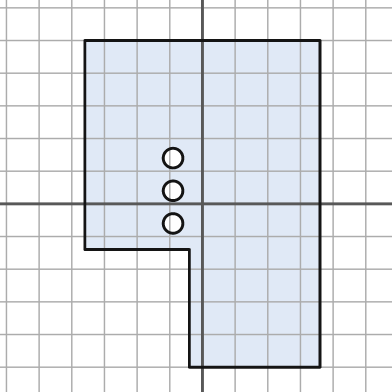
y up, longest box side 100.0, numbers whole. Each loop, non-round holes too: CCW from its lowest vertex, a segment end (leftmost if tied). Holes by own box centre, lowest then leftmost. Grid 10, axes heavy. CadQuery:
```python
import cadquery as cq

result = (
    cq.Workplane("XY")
    .moveTo(-4.0, -50.0)
    .lineTo(36.0, -50.0)
    .lineTo(36.0, 50.0)
    .lineTo(-36.0, 50.0)
    .lineTo(-36.0, -14.0)
    .lineTo(-4.0, -14.0)
    .close()
    .moveTo(-9.0, -6.0)
    .circle(3.0)
    .moveTo(-9.0, 4.0)
    .circle(3.0)
    .moveTo(-9.0, 14.0)
    .circle(3.0)
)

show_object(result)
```